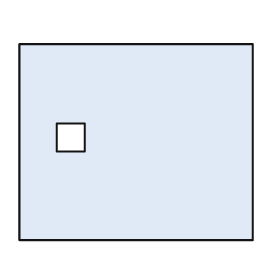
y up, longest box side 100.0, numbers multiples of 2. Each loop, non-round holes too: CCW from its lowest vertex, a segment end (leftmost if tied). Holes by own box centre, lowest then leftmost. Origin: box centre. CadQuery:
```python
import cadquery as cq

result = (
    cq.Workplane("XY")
    .moveTo(-50.0, -42.0)
    .lineTo(50.0, -42.0)
    .lineTo(50.0, 42.0)
    .lineTo(-50.0, 42.0)
    .close()
    .moveTo(-34.0, -4.0)
    .lineTo(-22.0, -4.0)
    .lineTo(-22.0, 8.0)
    .lineTo(-34.0, 8.0)
    .close()
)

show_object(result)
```